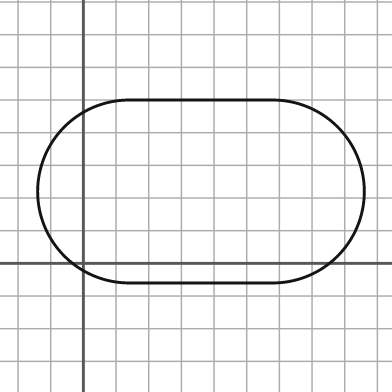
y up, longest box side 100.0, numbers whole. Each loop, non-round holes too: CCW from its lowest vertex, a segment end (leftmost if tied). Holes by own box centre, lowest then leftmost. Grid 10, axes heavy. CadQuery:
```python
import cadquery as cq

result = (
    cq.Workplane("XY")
    .moveTo(14.0, -6.0)
    .lineTo(58.0, -6.0)
    .threePointArc((86.0, 22.0), (58.0, 50.0))
    .lineTo(14.0, 50.0)
    .threePointArc((-14.0, 22.0), (14.0, -6.0))
    .close()
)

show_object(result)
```